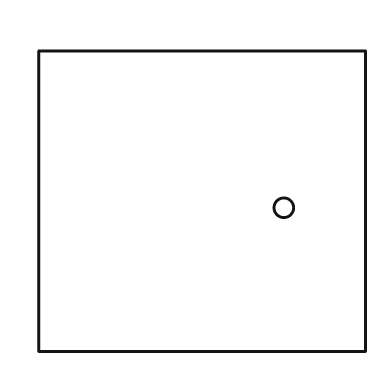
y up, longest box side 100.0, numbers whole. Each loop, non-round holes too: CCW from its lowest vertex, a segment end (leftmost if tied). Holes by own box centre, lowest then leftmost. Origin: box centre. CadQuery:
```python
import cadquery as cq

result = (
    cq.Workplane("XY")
    .moveTo(-50.0, -46.0)
    .lineTo(50.0, -46.0)
    .lineTo(50.0, 46.0)
    .lineTo(-50.0, 46.0)
    .close()
    .moveTo(25.0, -2.0)
    .circle(3.0)
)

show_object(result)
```